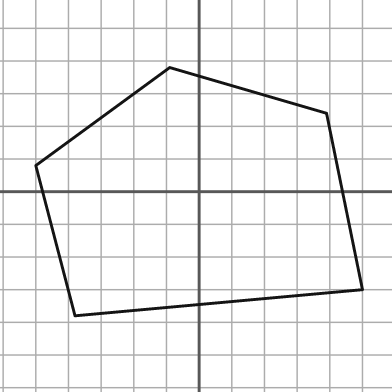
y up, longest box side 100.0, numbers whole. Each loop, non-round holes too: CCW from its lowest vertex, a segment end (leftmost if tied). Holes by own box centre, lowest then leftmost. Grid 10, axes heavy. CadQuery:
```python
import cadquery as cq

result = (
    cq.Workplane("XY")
    .moveTo(-38.0, -38.0)
    .lineTo(50.0, -30.0)
    .lineTo(39.0, 24.0)
    .lineTo(-9.0, 38.0)
    .lineTo(-50.0, 8.0)
    .close()
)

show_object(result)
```